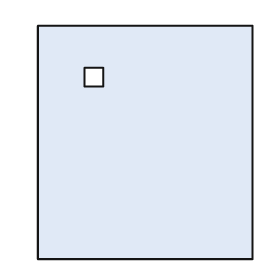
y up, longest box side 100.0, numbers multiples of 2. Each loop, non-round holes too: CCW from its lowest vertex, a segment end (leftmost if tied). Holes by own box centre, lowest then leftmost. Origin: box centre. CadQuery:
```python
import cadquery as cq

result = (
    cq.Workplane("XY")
    .moveTo(-46.0, -50.0)
    .lineTo(46.0, -50.0)
    .lineTo(46.0, 50.0)
    .lineTo(-46.0, 50.0)
    .close()
    .moveTo(-26.0, 24.0)
    .lineTo(-18.0, 24.0)
    .lineTo(-18.0, 32.0)
    .lineTo(-26.0, 32.0)
    .close()
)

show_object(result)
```